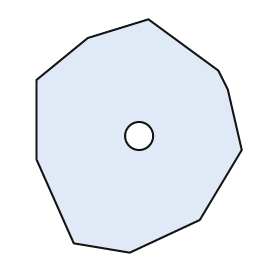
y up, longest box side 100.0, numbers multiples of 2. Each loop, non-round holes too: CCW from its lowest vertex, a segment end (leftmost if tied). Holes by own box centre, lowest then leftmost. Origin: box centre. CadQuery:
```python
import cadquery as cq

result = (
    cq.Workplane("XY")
    .moveTo(-4.0, -50.0)
    .lineTo(26.0, -36.0)
    .lineTo(44.0, -6.0)
    .lineTo(38.0, 20.0)
    .lineTo(34.0, 28.0)
    .lineTo(4.0, 50.0)
    .lineTo(-22.0, 42.0)
    .lineTo(-44.0, 24.0)
    .lineTo(-44.0, -10.0)
    .lineTo(-28.0, -46.0)
    .close()
    .moveTo(0.0, 0.0)
    .circle(6.0)
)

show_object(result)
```